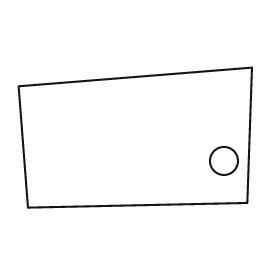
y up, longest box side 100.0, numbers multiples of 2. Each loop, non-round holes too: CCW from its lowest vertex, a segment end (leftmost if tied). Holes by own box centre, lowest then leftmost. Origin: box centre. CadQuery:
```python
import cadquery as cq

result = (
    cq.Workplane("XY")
    .moveTo(-46.0, -30.0)
    .lineTo(48.0, -28.0)
    .lineTo(50.0, 30.0)
    .lineTo(-50.0, 22.0)
    .close()
    .moveTo(38.0, -10.0)
    .circle(6.0)
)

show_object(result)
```